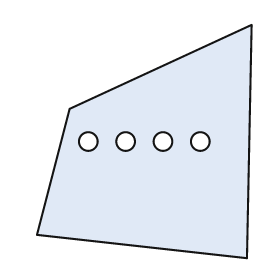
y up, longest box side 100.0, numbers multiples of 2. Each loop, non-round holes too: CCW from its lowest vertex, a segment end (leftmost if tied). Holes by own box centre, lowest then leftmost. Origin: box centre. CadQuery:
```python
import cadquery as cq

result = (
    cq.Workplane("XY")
    .moveTo(44.0, -50.0)
    .lineTo(46.0, 50.0)
    .lineTo(-32.0, 14.0)
    .lineTo(-46.0, -40.0)
    .close()
    .moveTo(-24.0, 0.0)
    .circle(4.0)
    .moveTo(-8.0, 0.0)
    .circle(4.0)
    .moveTo(8.0, 0.0)
    .circle(4.0)
    .moveTo(24.0, 0.0)
    .circle(4.0)
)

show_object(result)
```